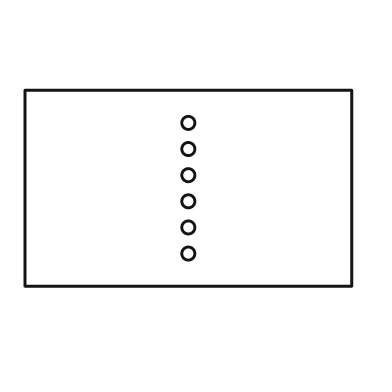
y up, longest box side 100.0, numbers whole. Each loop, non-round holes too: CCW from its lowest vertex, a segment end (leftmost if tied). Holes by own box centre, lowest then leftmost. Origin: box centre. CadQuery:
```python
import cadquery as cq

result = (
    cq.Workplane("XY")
    .moveTo(-50.0, -30.0)
    .lineTo(50.0, -30.0)
    .lineTo(50.0, 30.0)
    .lineTo(-50.0, 30.0)
    .close()
    .moveTo(0.0, -20.0)
    .circle(2.0)
    .moveTo(0.0, -12.0)
    .circle(2.0)
    .moveTo(0.0, -4.0)
    .circle(2.0)
    .moveTo(0.0, 4.0)
    .circle(2.0)
    .moveTo(0.0, 12.0)
    .circle(2.0)
    .moveTo(0.0, 20.0)
    .circle(2.0)
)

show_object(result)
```